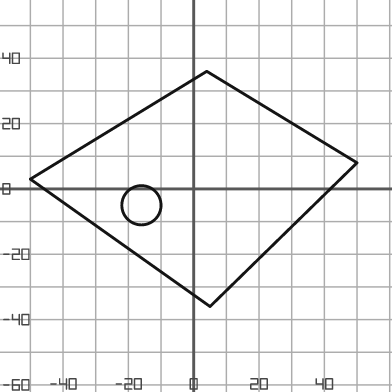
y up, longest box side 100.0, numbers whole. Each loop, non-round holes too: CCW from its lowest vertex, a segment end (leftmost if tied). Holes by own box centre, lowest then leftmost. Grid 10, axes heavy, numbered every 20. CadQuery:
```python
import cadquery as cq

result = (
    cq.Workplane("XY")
    .moveTo(5.0, -36.0)
    .lineTo(50.0, 8.0)
    .lineTo(4.0, 36.0)
    .lineTo(-50.0, 3.0)
    .close()
    .moveTo(-16.0, -5.0)
    .circle(6.0)
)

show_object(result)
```